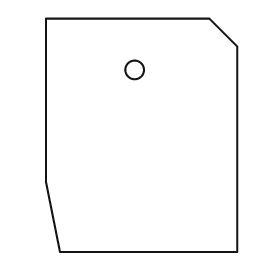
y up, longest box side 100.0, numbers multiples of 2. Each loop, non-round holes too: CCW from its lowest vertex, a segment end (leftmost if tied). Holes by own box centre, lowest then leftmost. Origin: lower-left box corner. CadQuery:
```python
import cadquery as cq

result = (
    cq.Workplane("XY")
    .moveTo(6.0, 0.0)
    .lineTo(82.0, 0.0)
    .lineTo(82.0, 88.0)
    .lineTo(70.0, 100.0)
    .lineTo(0.0, 100.0)
    .lineTo(0.0, 30.0)
    .close()
    .moveTo(38.0, 78.0)
    .circle(4.0)
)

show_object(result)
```